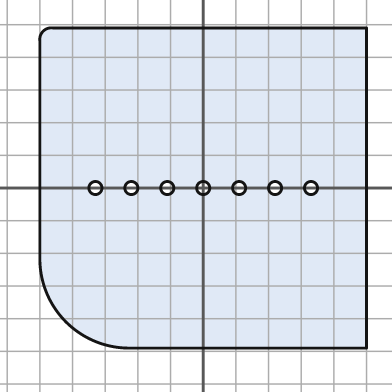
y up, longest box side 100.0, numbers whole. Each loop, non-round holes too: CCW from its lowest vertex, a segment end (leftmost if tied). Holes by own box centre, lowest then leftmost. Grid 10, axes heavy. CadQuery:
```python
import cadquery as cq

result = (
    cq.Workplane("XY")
    .moveTo(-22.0, -49.0)
    .lineTo(50.0, -49.0)
    .lineTo(50.0, 49.0)
    .lineTo(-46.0, 49.0)
    .threePointArc((-49.0, 48.0), (-50.0, 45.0))
    .lineTo(-50.0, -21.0)
    .threePointArc((-42.0, -41.0), (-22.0, -49.0))
    .close()
    .moveTo(-33.0, 0.0)
    .circle(2.0)
    .moveTo(-22.0, 0.0)
    .circle(2.0)
    .moveTo(-11.0, 0.0)
    .circle(2.0)
    .moveTo(0.0, 0.0)
    .circle(2.0)
    .moveTo(11.0, 0.0)
    .circle(2.0)
    .moveTo(22.0, 0.0)
    .circle(2.0)
    .moveTo(33.0, 0.0)
    .circle(2.0)
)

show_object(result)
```